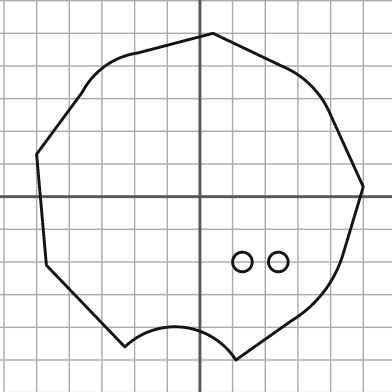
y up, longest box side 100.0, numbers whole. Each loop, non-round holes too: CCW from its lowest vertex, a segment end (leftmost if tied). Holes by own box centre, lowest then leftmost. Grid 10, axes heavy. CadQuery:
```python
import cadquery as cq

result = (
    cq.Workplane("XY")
    .moveTo(11.0, -50.0)
    .lineTo(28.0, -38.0)
    .threePointArc((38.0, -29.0), (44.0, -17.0))
    .lineTo(50.0, 3.0)
    .lineTo(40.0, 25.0)
    .threePointArc((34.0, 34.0), (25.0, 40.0))
    .lineTo(4.0, 50.0)
    .lineTo(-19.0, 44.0)
    .threePointArc((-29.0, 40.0), (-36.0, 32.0))
    .lineTo(-50.0, 13.0)
    .lineTo(-47.0, -21.0)
    .lineTo(-23.0, -46.0)
    .threePointArc((-5.0, -40.0), (11.0, -50.0))
    .close()
    .moveTo(13.0, -20.0)
    .circle(3.0)
    .moveTo(24.0, -20.0)
    .circle(3.0)
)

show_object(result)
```